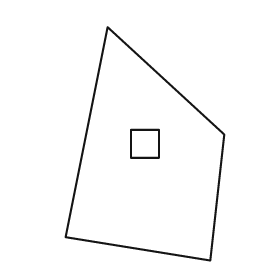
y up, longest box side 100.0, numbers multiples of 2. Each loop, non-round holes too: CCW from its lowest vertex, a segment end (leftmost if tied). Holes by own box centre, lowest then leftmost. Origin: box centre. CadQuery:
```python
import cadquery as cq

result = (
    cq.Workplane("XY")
    .moveTo(28.0, -50.0)
    .lineTo(34.0, 4.0)
    .lineTo(-16.0, 50.0)
    .lineTo(-34.0, -40.0)
    .close()
    .moveTo(-6.0, -6.0)
    .lineTo(6.0, -6.0)
    .lineTo(6.0, 6.0)
    .lineTo(-6.0, 6.0)
    .close()
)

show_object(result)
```